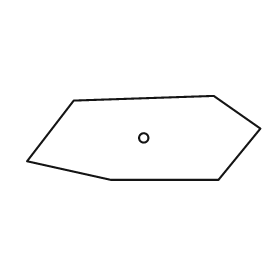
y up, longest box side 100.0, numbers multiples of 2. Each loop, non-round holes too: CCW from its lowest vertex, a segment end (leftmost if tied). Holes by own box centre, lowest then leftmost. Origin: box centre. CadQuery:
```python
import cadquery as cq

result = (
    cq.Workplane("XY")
    .moveTo(-14.0, -18.0)
    .lineTo(32.0, -18.0)
    .lineTo(50.0, 4.0)
    .lineTo(30.0, 18.0)
    .lineTo(-30.0, 16.0)
    .lineTo(-50.0, -10.0)
    .close()
    .moveTo(0.0, 0.0)
    .circle(2.0)
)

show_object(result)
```